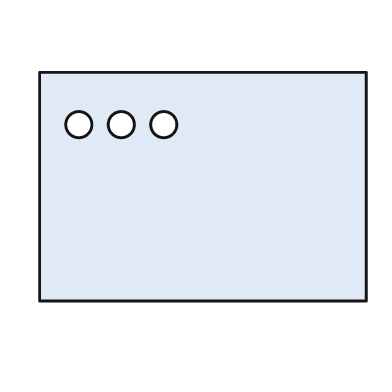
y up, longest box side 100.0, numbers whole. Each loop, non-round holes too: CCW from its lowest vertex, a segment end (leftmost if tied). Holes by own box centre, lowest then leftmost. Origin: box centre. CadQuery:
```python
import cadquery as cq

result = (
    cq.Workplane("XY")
    .moveTo(-50.0, -35.0)
    .lineTo(50.0, -35.0)
    .lineTo(50.0, 35.0)
    .lineTo(-50.0, 35.0)
    .close()
    .moveTo(-38.0, 19.0)
    .circle(4.0)
    .moveTo(-25.0, 19.0)
    .circle(4.0)
    .moveTo(-12.0, 19.0)
    .circle(4.0)
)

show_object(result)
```